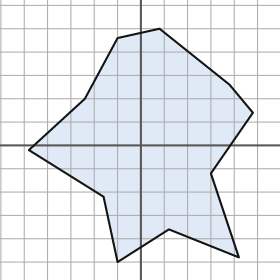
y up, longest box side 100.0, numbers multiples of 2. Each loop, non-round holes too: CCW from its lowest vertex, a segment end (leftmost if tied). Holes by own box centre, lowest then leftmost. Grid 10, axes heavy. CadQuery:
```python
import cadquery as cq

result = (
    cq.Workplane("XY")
    .moveTo(-10.0, -50.0)
    .lineTo(12.0, -36.0)
    .lineTo(42.0, -48.0)
    .lineTo(30.0, -12.0)
    .lineTo(48.0, 14.0)
    .lineTo(38.0, 26.0)
    .lineTo(8.0, 50.0)
    .lineTo(-10.0, 46.0)
    .lineTo(-24.0, 20.0)
    .lineTo(-48.0, -2.0)
    .lineTo(-16.0, -22.0)
    .close()
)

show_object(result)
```